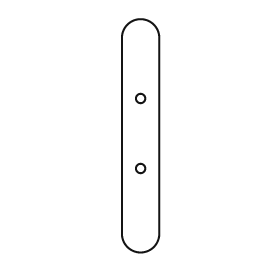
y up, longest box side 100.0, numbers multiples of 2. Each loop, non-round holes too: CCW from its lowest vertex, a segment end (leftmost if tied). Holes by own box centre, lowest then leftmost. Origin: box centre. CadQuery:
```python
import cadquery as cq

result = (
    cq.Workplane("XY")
    .moveTo(-8.0, -42.0)
    .threePointArc((0.0, -50.0), (8.0, -42.0))
    .lineTo(8.0, 42.0)
    .threePointArc((0.0, 50.0), (-8.0, 42.0))
    .close()
    .moveTo(0.0, -14.0)
    .circle(2.0)
    .moveTo(0.0, 16.0)
    .circle(2.0)
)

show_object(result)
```